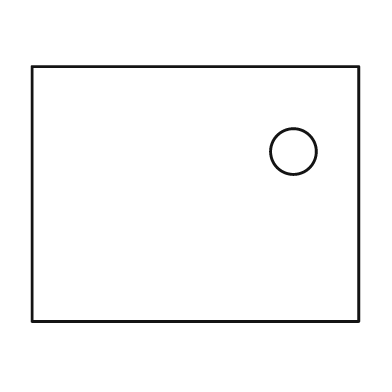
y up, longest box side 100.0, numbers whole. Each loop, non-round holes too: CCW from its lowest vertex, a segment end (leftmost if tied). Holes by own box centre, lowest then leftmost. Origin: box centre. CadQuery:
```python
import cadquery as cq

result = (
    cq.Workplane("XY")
    .moveTo(-50.0, -39.0)
    .lineTo(50.0, -39.0)
    .lineTo(50.0, 39.0)
    .lineTo(-50.0, 39.0)
    .close()
    .moveTo(30.0, 13.0)
    .circle(7.0)
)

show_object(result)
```